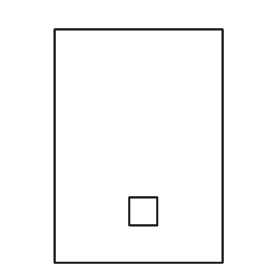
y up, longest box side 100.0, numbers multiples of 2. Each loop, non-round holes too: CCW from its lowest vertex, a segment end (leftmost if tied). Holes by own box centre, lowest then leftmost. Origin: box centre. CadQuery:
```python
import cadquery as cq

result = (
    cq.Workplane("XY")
    .moveTo(-36.0, -50.0)
    .lineTo(36.0, -50.0)
    .lineTo(36.0, 50.0)
    .lineTo(-36.0, 50.0)
    .close()
    .moveTo(-4.0, -34.0)
    .lineTo(8.0, -34.0)
    .lineTo(8.0, -22.0)
    .lineTo(-4.0, -22.0)
    .close()
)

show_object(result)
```